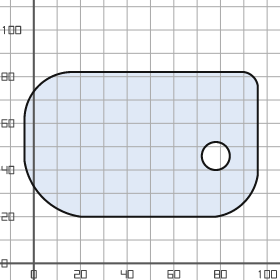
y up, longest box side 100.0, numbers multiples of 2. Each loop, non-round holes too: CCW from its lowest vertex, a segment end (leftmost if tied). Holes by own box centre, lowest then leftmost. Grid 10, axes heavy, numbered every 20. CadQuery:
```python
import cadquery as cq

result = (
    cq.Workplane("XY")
    .moveTo(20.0, 20.0)
    .lineTo(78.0, 20.0)
    .threePointArc((90.0, 26.0), (96.0, 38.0))
    .lineTo(96.0, 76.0)
    .threePointArc((94.0, 80.0), (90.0, 82.0))
    .lineTo(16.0, 82.0)
    .threePointArc((2.0, 76.0), (-4.0, 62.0))
    .lineTo(-4.0, 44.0)
    .threePointArc((4.0, 28.0), (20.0, 20.0))
    .close()
    .moveTo(78.0, 46.0)
    .circle(6.0)
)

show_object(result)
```